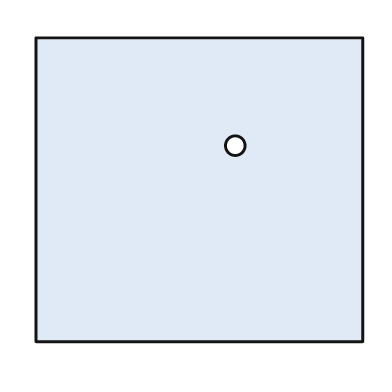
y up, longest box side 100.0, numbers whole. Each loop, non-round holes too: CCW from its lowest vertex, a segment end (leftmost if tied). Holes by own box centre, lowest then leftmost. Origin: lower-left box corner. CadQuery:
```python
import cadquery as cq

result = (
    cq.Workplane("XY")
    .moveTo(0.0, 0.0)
    .lineTo(100.0, 0.0)
    .lineTo(100.0, 93.0)
    .lineTo(0.0, 93.0)
    .close()
    .moveTo(61.0, 60.0)
    .circle(3.0)
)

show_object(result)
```